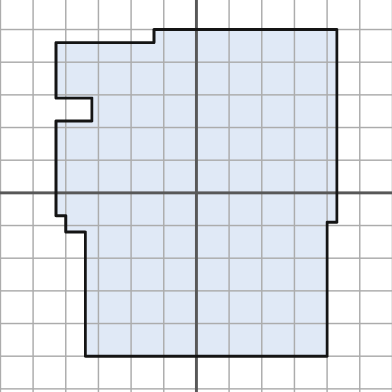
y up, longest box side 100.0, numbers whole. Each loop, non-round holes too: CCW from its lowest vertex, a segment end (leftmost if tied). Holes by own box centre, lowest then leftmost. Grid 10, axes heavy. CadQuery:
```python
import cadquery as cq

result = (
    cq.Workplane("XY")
    .moveTo(-34.0, -50.0)
    .lineTo(40.0, -50.0)
    .lineTo(40.0, -9.0)
    .lineTo(43.0, -9.0)
    .lineTo(43.0, 50.0)
    .lineTo(-13.0, 50.0)
    .lineTo(-13.0, 46.0)
    .lineTo(-43.0, 46.0)
    .lineTo(-43.0, 29.0)
    .lineTo(-32.0, 29.0)
    .lineTo(-32.0, 22.0)
    .lineTo(-43.0, 22.0)
    .lineTo(-43.0, -7.0)
    .lineTo(-40.0, -7.0)
    .lineTo(-40.0, -12.0)
    .lineTo(-34.0, -12.0)
    .close()
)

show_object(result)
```